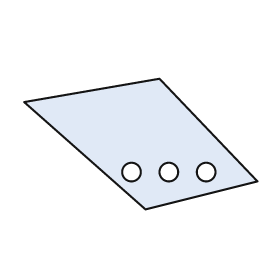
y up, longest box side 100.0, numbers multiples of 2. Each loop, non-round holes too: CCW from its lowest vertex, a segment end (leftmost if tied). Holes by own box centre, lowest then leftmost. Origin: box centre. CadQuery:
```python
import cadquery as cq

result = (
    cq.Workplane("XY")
    .moveTo(2.0, -28.0)
    .lineTo(50.0, -16.0)
    .lineTo(8.0, 28.0)
    .lineTo(-50.0, 18.0)
    .close()
    .moveTo(-4.0, -12.0)
    .circle(4.0)
    .moveTo(12.0, -12.0)
    .circle(4.0)
    .moveTo(28.0, -12.0)
    .circle(4.0)
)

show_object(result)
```